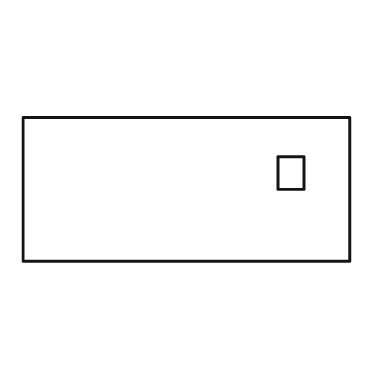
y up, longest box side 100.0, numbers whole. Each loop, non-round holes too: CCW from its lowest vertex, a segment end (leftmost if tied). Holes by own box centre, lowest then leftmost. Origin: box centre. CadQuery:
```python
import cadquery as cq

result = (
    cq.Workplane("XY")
    .moveTo(-50.0, -22.0)
    .lineTo(50.0, -22.0)
    .lineTo(50.0, 22.0)
    .lineTo(-50.0, 22.0)
    .close()
    .moveTo(28.0, 0.0)
    .lineTo(36.0, 0.0)
    .lineTo(36.0, 10.0)
    .lineTo(28.0, 10.0)
    .close()
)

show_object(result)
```